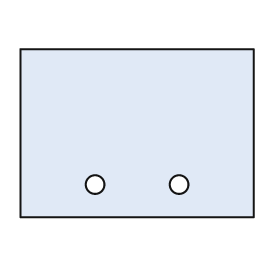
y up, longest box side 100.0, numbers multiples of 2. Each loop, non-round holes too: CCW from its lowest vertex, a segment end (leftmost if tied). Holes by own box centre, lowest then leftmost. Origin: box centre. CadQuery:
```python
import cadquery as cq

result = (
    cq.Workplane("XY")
    .moveTo(-50.0, -36.0)
    .lineTo(50.0, -36.0)
    .lineTo(50.0, 36.0)
    .lineTo(-50.0, 36.0)
    .close()
    .moveTo(-18.0, -22.0)
    .circle(4.0)
    .moveTo(18.0, -22.0)
    .circle(4.0)
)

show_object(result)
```